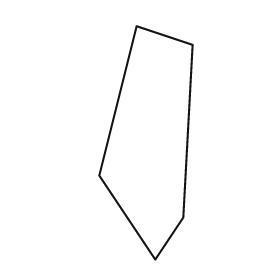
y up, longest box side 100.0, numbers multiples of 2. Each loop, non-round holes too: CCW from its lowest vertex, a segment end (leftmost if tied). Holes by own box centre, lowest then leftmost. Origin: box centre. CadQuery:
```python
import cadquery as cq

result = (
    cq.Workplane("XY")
    .moveTo(4.0, -50.0)
    .lineTo(16.0, -32.0)
    .lineTo(20.0, 42.0)
    .lineTo(-4.0, 50.0)
    .lineTo(-20.0, -14.0)
    .close()
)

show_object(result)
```